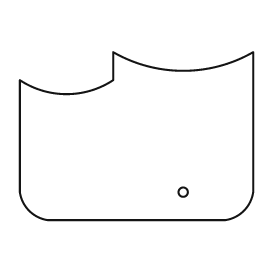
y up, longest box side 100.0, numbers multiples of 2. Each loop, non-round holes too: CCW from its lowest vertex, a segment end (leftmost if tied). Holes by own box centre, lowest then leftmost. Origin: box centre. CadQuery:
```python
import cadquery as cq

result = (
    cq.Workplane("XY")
    .moveTo(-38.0, -36.0)
    .lineTo(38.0, -36.0)
    .threePointArc((46.0, -32.0), (50.0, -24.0))
    .lineTo(50.0, 36.0)
    .threePointArc((20.0, 28.0), (-10.0, 36.0))
    .lineTo(-10.0, 24.0)
    .threePointArc((-30.0, 18.0), (-50.0, 24.0))
    .lineTo(-50.0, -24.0)
    .threePointArc((-46.0, -32.0), (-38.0, -36.0))
    .close()
    .moveTo(20.0, -24.0)
    .circle(2.0)
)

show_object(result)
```